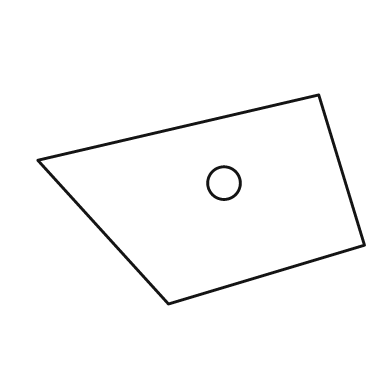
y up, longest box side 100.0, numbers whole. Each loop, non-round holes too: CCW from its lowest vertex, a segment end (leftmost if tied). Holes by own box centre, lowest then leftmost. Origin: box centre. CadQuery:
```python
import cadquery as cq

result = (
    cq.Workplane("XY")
    .moveTo(-10.0, -32.0)
    .lineTo(50.0, -14.0)
    .lineTo(36.0, 32.0)
    .lineTo(-50.0, 12.0)
    .close()
    .moveTo(7.0, 5.0)
    .circle(5.0)
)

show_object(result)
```